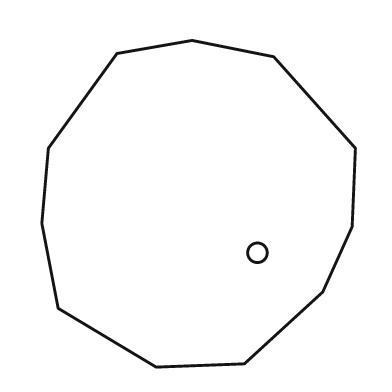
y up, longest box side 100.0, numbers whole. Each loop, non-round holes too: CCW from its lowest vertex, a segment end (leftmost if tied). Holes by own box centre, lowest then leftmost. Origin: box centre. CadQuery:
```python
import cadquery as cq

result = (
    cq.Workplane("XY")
    .moveTo(-13.0, -50.0)
    .lineTo(14.0, -49.0)
    .lineTo(38.0, -27.0)
    .lineTo(47.0, -7.0)
    .lineTo(48.0, 17.0)
    .lineTo(23.0, 45.0)
    .lineTo(-2.0, 50.0)
    .lineTo(-25.0, 46.0)
    .lineTo(-46.0, 17.0)
    .lineTo(-48.0, -6.0)
    .lineTo(-43.0, -32.0)
    .close()
    .moveTo(18.0, -15.0)
    .circle(3.0)
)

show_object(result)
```